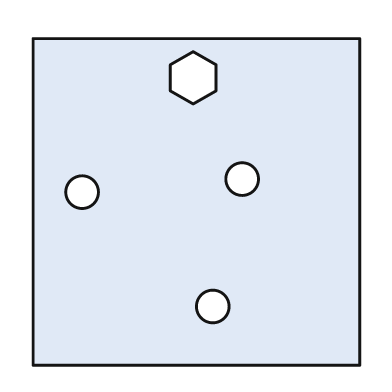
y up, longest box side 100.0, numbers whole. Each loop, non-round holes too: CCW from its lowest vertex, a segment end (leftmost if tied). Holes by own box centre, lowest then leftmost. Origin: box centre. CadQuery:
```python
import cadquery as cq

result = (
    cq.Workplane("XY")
    .moveTo(-50.0, -50.0)
    .lineTo(50.0, -50.0)
    .lineTo(50.0, 50.0)
    .lineTo(-50.0, 50.0)
    .close()
    .moveTo(5.0, -32.0)
    .circle(5.0)
    .moveTo(-35.0, 3.0)
    .circle(5.0)
    .moveTo(14.0, 7.0)
    .circle(5.0)
    .moveTo(-1.0, 30.0)
    .lineTo(6.0, 34.0)
    .lineTo(6.0, 42.0)
    .lineTo(-1.0, 46.0)
    .lineTo(-8.0, 42.0)
    .lineTo(-8.0, 34.0)
    .close()
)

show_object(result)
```